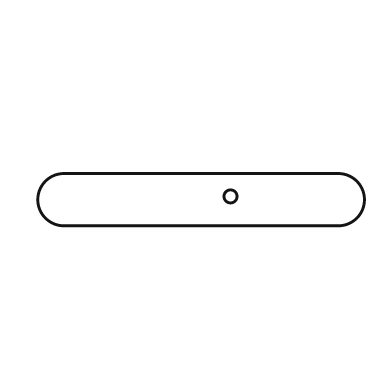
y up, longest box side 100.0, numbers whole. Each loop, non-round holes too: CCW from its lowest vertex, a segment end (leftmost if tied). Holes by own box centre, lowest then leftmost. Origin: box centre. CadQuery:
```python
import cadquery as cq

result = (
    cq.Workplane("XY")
    .moveTo(-42.0, -8.0)
    .lineTo(42.0, -8.0)
    .threePointArc((50.0, 0.0), (42.0, 8.0))
    .lineTo(-42.0, 8.0)
    .threePointArc((-50.0, 0.0), (-42.0, -8.0))
    .close()
    .moveTo(9.0, 1.0)
    .circle(2.0)
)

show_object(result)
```